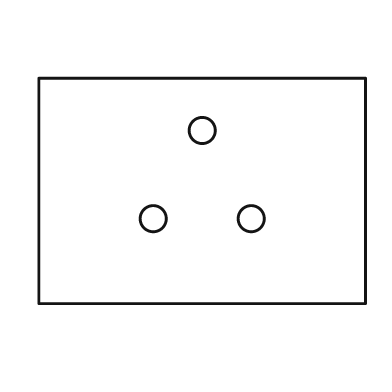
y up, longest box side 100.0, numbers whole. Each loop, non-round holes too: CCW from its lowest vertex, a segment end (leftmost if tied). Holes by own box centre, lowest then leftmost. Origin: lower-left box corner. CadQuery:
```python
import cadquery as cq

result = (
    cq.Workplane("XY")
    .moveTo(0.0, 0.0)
    .lineTo(100.0, 0.0)
    .lineTo(100.0, 69.0)
    .lineTo(0.0, 69.0)
    .close()
    .moveTo(35.0, 26.0)
    .circle(4.0)
    .moveTo(65.0, 26.0)
    .circle(4.0)
    .moveTo(50.0, 53.0)
    .circle(4.0)
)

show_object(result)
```